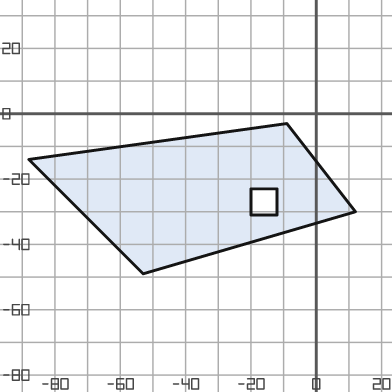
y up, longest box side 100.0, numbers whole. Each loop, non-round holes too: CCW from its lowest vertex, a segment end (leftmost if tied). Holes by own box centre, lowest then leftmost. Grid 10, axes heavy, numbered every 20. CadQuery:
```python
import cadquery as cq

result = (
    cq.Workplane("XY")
    .moveTo(-53.0, -49.0)
    .lineTo(12.0, -30.0)
    .lineTo(-9.0, -3.0)
    .lineTo(-88.0, -14.0)
    .close()
    .moveTo(-20.0, -31.0)
    .lineTo(-12.0, -31.0)
    .lineTo(-12.0, -23.0)
    .lineTo(-20.0, -23.0)
    .close()
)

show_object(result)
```